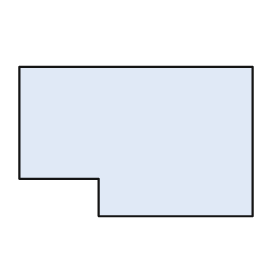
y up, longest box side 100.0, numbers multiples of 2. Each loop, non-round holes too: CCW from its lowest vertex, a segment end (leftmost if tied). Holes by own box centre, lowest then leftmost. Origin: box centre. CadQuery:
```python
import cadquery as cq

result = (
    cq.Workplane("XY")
    .moveTo(-16.0, -32.0)
    .lineTo(50.0, -32.0)
    .lineTo(50.0, 32.0)
    .lineTo(-50.0, 32.0)
    .lineTo(-50.0, -16.0)
    .lineTo(-16.0, -16.0)
    .close()
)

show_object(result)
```